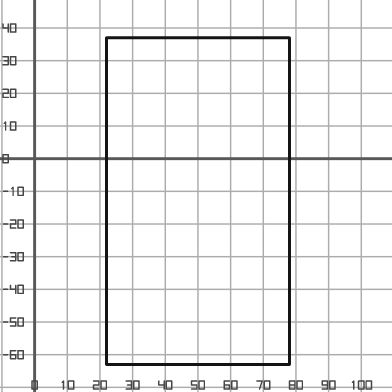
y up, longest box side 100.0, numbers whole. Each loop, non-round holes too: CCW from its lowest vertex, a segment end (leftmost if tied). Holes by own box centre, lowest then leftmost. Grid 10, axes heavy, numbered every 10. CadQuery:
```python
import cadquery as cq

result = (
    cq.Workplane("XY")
    .moveTo(22.0, -63.0)
    .lineTo(78.0, -63.0)
    .lineTo(78.0, 37.0)
    .lineTo(22.0, 37.0)
    .close()
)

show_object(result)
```